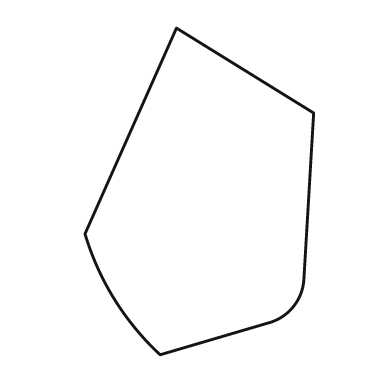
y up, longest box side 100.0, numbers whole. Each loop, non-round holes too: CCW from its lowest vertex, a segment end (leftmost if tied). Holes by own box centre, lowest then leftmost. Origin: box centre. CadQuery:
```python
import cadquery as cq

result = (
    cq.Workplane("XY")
    .moveTo(-12.0, -50.0)
    .lineTo(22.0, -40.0)
    .threePointArc((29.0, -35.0), (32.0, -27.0))
    .lineTo(35.0, 24.0)
    .lineTo(-7.0, 50.0)
    .lineTo(-35.0, -13.0)
    .threePointArc((-26.0, -33.0), (-12.0, -50.0))
    .close()
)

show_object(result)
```